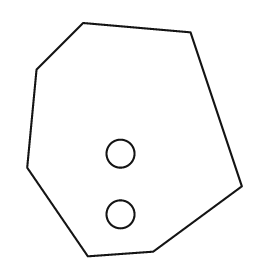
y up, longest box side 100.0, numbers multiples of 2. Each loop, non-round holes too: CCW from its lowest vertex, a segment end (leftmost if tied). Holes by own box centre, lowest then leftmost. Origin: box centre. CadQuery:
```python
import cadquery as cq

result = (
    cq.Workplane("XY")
    .moveTo(-20.0, -50.0)
    .lineTo(8.0, -48.0)
    .lineTo(46.0, -20.0)
    .lineTo(24.0, 46.0)
    .lineTo(-22.0, 50.0)
    .lineTo(-42.0, 30.0)
    .lineTo(-46.0, -12.0)
    .close()
    .moveTo(-6.0, -32.0)
    .circle(6.0)
    .moveTo(-6.0, -6.0)
    .circle(6.0)
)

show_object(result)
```